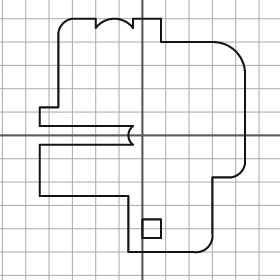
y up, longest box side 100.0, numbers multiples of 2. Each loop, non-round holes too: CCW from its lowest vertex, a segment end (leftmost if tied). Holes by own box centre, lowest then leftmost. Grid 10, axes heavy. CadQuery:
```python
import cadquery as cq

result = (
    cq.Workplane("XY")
    .moveTo(-6.0, -50.0)
    .lineTo(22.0, -50.0)
    .threePointArc((28.0, -48.0), (30.0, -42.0))
    .lineTo(30.0, -18.0)
    .lineTo(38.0, -18.0)
    .threePointArc((42.0, -16.0), (44.0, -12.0))
    .lineTo(44.0, 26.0)
    .threePointArc((40.0, 36.0), (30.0, 40.0))
    .lineTo(8.0, 40.0)
    .lineTo(8.0, 50.0)
    .lineTo(-4.0, 50.0)
    .lineTo(-4.0, 46.0)
    .threePointArc((-12.0, 50.0), (-20.0, 46.0))
    .lineTo(-20.0, 50.0)
    .lineTo(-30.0, 50.0)
    .threePointArc((-34.0, 48.0), (-36.0, 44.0))
    .lineTo(-36.0, 12.0)
    .lineTo(-44.0, 12.0)
    .lineTo(-44.0, 4.0)
    .lineTo(-4.0, 4.0)
    .threePointArc((-6.0, 0.0), (-4.0, -4.0))
    .lineTo(-44.0, -4.0)
    .lineTo(-44.0, -26.0)
    .lineTo(-6.0, -26.0)
    .close()
    .moveTo(0.0, -44.0)
    .lineTo(8.0, -44.0)
    .lineTo(8.0, -36.0)
    .lineTo(0.0, -36.0)
    .close()
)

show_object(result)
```